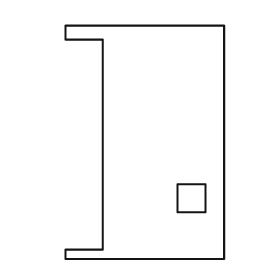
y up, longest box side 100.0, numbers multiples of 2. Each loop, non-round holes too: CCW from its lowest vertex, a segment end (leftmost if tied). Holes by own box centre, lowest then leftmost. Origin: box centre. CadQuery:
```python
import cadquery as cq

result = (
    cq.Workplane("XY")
    .moveTo(-34.0, -50.0)
    .lineTo(34.0, -50.0)
    .lineTo(34.0, 50.0)
    .lineTo(-34.0, 50.0)
    .lineTo(-34.0, 44.0)
    .lineTo(-18.0, 44.0)
    .lineTo(-18.0, -46.0)
    .lineTo(-34.0, -46.0)
    .close()
    .moveTo(14.0, -30.0)
    .lineTo(26.0, -30.0)
    .lineTo(26.0, -18.0)
    .lineTo(14.0, -18.0)
    .close()
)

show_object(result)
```